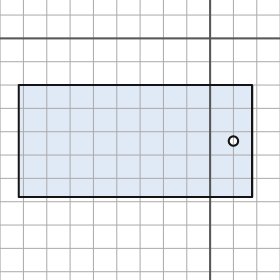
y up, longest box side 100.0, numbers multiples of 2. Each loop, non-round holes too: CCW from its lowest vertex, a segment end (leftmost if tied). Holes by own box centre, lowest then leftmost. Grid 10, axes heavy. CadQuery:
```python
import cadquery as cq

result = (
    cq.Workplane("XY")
    .moveTo(-82.0, -68.0)
    .lineTo(18.0, -68.0)
    .lineTo(18.0, -20.0)
    .lineTo(-82.0, -20.0)
    .close()
    .moveTo(10.0, -44.0)
    .circle(2.0)
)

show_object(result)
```